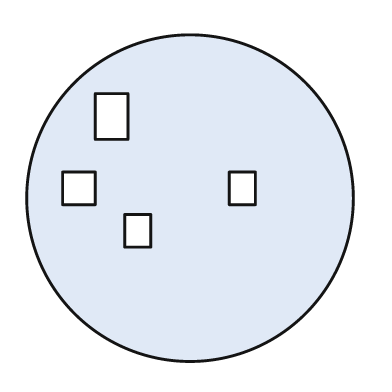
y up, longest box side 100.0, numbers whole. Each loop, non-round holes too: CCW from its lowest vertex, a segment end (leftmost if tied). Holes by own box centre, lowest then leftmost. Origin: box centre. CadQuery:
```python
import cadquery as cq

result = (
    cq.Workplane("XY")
    .moveTo(0.0, 0.0)
    .circle(50.0)
    .moveTo(-20.0, -15.0)
    .lineTo(-12.0, -15.0)
    .lineTo(-12.0, -5.0)
    .lineTo(-20.0, -5.0)
    .close()
    .moveTo(-39.0, -2.0)
    .lineTo(-29.0, -2.0)
    .lineTo(-29.0, 8.0)
    .lineTo(-39.0, 8.0)
    .close()
    .moveTo(12.0, -2.0)
    .lineTo(20.0, -2.0)
    .lineTo(20.0, 8.0)
    .lineTo(12.0, 8.0)
    .close()
    .moveTo(-29.0, 18.0)
    .lineTo(-19.0, 18.0)
    .lineTo(-19.0, 32.0)
    .lineTo(-29.0, 32.0)
    .close()
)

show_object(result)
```